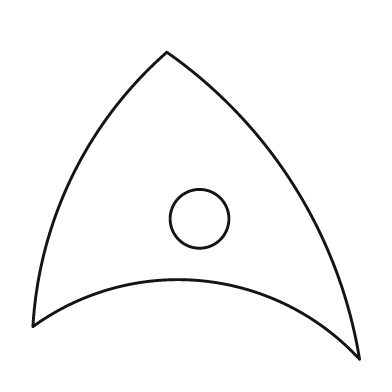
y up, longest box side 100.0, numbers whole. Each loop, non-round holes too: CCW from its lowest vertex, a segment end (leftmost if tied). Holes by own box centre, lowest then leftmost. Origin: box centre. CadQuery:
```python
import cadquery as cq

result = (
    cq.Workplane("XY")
    .moveTo(50.0, -47.0)
    .threePointArc((30.0, 6.0), (-9.0, 47.0))
    .threePointArc((-38.0, 9.0), (-50.0, -37.0))
    .threePointArc((2.0, -23.0), (50.0, -47.0))
    .close()
    .moveTo(1.0, -4.0)
    .circle(9.0)
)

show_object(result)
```